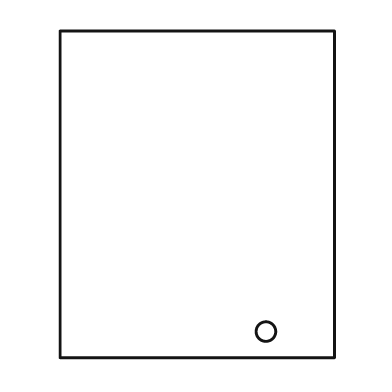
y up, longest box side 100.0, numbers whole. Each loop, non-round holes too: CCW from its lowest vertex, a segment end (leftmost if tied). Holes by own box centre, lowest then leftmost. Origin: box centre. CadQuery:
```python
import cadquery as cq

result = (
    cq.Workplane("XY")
    .moveTo(-42.0, -50.0)
    .lineTo(42.0, -50.0)
    .lineTo(42.0, 50.0)
    .lineTo(-42.0, 50.0)
    .close()
    .moveTo(21.0, -42.0)
    .circle(3.0)
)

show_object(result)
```